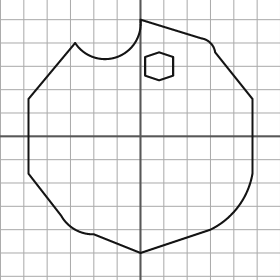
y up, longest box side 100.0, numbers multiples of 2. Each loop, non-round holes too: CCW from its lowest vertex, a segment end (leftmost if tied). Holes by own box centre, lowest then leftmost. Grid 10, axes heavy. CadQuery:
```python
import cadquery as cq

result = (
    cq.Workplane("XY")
    .moveTo(0.0, -50.0)
    .lineTo(30.0, -40.0)
    .threePointArc((42.0, -30.0), (48.0, -16.0))
    .lineTo(48.0, 16.0)
    .lineTo(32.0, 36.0)
    .threePointArc((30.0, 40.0), (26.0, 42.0))
    .lineTo(0.0, 50.0)
    .threePointArc((-10.0, 34.0), (-28.0, 40.0))
    .lineTo(-48.0, 16.0)
    .lineTo(-48.0, -16.0)
    .lineTo(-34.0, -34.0)
    .threePointArc((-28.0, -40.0), (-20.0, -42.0))
    .close()
    .moveTo(8.0, 24.0)
    .lineTo(14.0, 26.0)
    .lineTo(14.0, 34.0)
    .lineTo(8.0, 36.0)
    .lineTo(2.0, 34.0)
    .lineTo(2.0, 26.0)
    .close()
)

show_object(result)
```